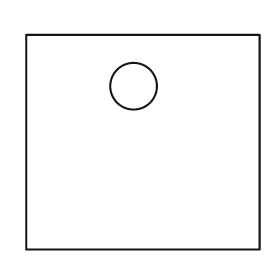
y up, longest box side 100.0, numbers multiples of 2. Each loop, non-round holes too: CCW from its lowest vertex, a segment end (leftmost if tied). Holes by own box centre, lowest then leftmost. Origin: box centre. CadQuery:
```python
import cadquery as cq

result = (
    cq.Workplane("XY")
    .moveTo(-50.0, -46.0)
    .lineTo(50.0, -46.0)
    .lineTo(50.0, 46.0)
    .lineTo(-50.0, 46.0)
    .close()
    .moveTo(-4.0, 24.0)
    .circle(10.0)
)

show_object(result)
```